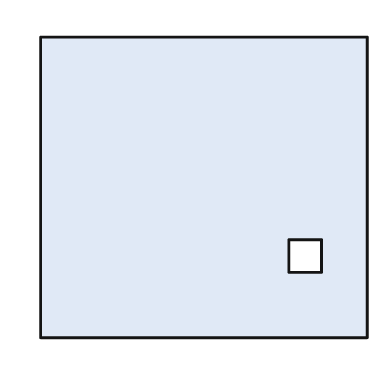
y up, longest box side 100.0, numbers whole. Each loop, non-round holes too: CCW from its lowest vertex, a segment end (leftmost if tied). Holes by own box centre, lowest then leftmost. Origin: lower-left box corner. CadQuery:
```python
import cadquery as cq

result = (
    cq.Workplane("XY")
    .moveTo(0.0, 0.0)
    .lineTo(100.0, 0.0)
    .lineTo(100.0, 92.0)
    .lineTo(0.0, 92.0)
    .close()
    .moveTo(76.0, 20.0)
    .lineTo(86.0, 20.0)
    .lineTo(86.0, 30.0)
    .lineTo(76.0, 30.0)
    .close()
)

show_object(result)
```